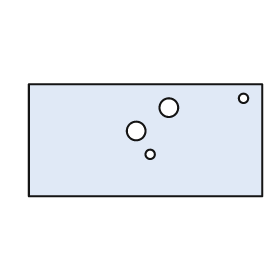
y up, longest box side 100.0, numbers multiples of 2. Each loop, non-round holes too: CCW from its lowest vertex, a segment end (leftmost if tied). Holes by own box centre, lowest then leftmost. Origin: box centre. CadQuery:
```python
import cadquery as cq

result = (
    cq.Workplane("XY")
    .moveTo(-50.0, -24.0)
    .lineTo(50.0, -24.0)
    .lineTo(50.0, 24.0)
    .lineTo(-50.0, 24.0)
    .close()
    .moveTo(2.0, -6.0)
    .circle(2.0)
    .moveTo(-4.0, 4.0)
    .circle(4.0)
    .moveTo(10.0, 14.0)
    .circle(4.0)
    .moveTo(42.0, 18.0)
    .circle(2.0)
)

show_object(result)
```